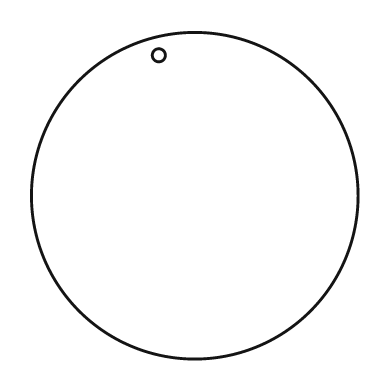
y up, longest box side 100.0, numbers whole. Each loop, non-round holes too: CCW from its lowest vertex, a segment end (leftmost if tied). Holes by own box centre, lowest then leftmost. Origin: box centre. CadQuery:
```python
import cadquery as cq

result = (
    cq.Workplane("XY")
    .moveTo(0.0, 0.0)
    .circle(50.0)
    .moveTo(-11.0, 43.0)
    .circle(2.0)
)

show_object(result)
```